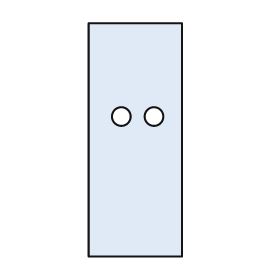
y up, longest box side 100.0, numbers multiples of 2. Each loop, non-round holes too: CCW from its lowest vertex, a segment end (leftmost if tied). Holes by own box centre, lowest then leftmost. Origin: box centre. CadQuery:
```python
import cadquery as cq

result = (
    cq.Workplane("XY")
    .moveTo(-20.0, -50.0)
    .lineTo(20.0, -50.0)
    .lineTo(20.0, 50.0)
    .lineTo(-20.0, 50.0)
    .close()
    .moveTo(-6.0, 10.0)
    .circle(4.0)
    .moveTo(8.0, 10.0)
    .circle(4.0)
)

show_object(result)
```